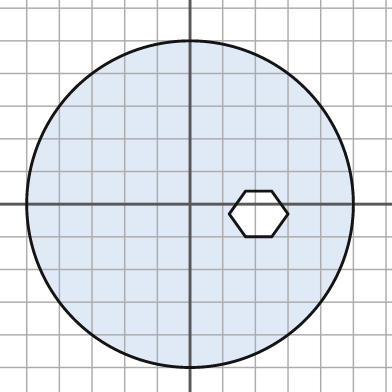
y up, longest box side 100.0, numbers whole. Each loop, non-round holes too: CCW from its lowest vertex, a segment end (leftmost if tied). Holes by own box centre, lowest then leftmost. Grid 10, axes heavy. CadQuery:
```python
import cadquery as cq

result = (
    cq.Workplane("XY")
    .moveTo(0.0, 0.0)
    .circle(50.0)
    .moveTo(17.0, -10.0)
    .lineTo(25.0, -10.0)
    .lineTo(30.0, -3.0)
    .lineTo(25.0, 4.0)
    .lineTo(17.0, 4.0)
    .lineTo(12.0, -3.0)
    .close()
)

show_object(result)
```